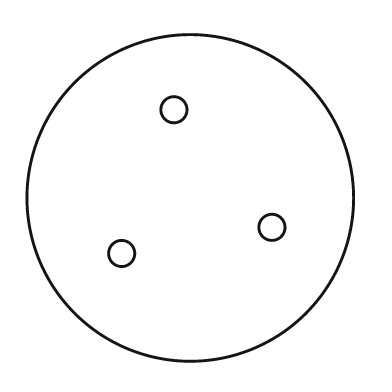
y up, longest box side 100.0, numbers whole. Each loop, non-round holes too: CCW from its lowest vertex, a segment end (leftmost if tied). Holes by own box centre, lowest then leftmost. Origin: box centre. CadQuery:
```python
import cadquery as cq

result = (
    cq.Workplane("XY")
    .moveTo(0.0, 0.0)
    .circle(50.0)
    .moveTo(-21.0, -17.0)
    .circle(4.0)
    .moveTo(25.0, -9.0)
    .circle(4.0)
    .moveTo(-5.0, 27.0)
    .circle(4.0)
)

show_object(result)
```